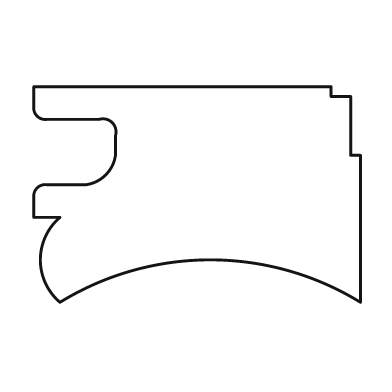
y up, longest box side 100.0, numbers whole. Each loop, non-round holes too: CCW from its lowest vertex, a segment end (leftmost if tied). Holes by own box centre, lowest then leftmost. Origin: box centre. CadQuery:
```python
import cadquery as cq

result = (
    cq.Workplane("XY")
    .moveTo(-42.0, -33.0)
    .threePointArc((4.0, -20.0), (50.0, -33.0))
    .lineTo(50.0, 12.0)
    .lineTo(47.0, 12.0)
    .lineTo(47.0, 30.0)
    .lineTo(41.0, 30.0)
    .lineTo(41.0, 33.0)
    .lineTo(-50.0, 33.0)
    .lineTo(-50.0, 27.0)
    .threePointArc((-49.0, 24.0), (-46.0, 23.0))
    .lineTo(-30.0, 23.0)
    .threePointArc((-26.0, 22.0), (-25.0, 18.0))
    .lineTo(-25.0, 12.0)
    .threePointArc((-28.0, 6.0), (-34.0, 3.0))
    .lineTo(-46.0, 3.0)
    .threePointArc((-49.0, 2.0), (-50.0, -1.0))
    .lineTo(-50.0, -7.0)
    .lineTo(-42.0, -7.0)
    .threePointArc((-48.0, -20.0), (-42.0, -33.0))
    .close()
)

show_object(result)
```